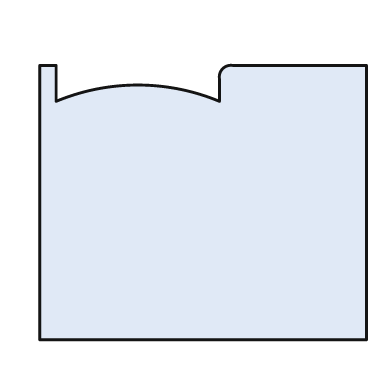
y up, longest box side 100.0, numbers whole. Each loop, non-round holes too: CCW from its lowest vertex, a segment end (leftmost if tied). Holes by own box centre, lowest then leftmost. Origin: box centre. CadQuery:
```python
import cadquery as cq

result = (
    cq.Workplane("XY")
    .moveTo(-50.0, -42.0)
    .lineTo(50.0, -42.0)
    .lineTo(50.0, 42.0)
    .lineTo(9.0, 42.0)
    .threePointArc((6.0, 41.0), (5.0, 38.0))
    .lineTo(5.0, 31.0)
    .threePointArc((-20.0, 36.0), (-45.0, 31.0))
    .lineTo(-45.0, 42.0)
    .lineTo(-50.0, 42.0)
    .close()
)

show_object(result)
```